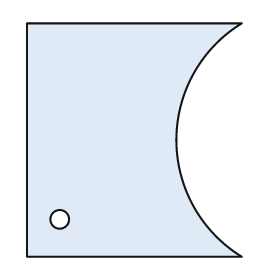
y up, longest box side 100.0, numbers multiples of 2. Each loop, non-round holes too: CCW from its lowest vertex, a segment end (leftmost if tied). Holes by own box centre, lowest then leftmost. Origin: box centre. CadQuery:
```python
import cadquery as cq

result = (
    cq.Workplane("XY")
    .moveTo(-46.0, -50.0)
    .lineTo(46.0, -50.0)
    .threePointArc((18.0, 0.0), (46.0, 50.0))
    .lineTo(-46.0, 50.0)
    .close()
    .moveTo(-32.0, -34.0)
    .circle(4.0)
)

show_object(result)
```